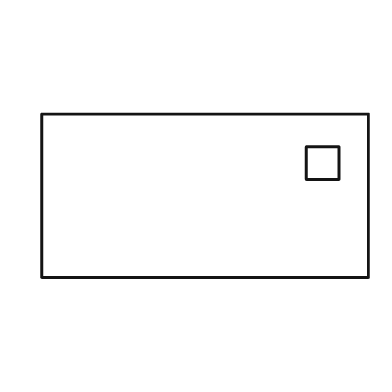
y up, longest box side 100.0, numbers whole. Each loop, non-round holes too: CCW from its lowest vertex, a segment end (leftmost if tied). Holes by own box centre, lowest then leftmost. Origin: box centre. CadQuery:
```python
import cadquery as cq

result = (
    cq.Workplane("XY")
    .moveTo(-50.0, -25.0)
    .lineTo(50.0, -25.0)
    .lineTo(50.0, 25.0)
    .lineTo(-50.0, 25.0)
    .close()
    .moveTo(31.0, 5.0)
    .lineTo(41.0, 5.0)
    .lineTo(41.0, 15.0)
    .lineTo(31.0, 15.0)
    .close()
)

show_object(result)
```